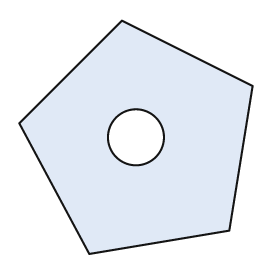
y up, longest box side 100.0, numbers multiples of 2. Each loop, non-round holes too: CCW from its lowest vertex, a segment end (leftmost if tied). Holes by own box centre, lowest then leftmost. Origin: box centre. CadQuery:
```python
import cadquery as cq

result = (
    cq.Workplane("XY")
    .moveTo(-20.0, -50.0)
    .lineTo(40.0, -40.0)
    .lineTo(50.0, 22.0)
    .lineTo(-6.0, 50.0)
    .lineTo(-50.0, 6.0)
    .close()
    .moveTo(0.0, 0.0)
    .circle(12.0)
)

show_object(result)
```